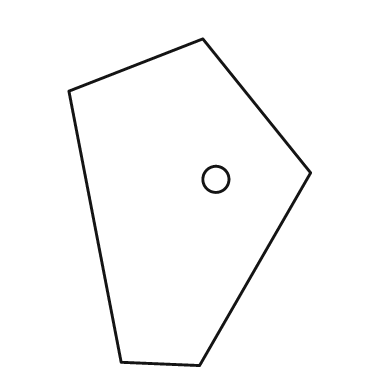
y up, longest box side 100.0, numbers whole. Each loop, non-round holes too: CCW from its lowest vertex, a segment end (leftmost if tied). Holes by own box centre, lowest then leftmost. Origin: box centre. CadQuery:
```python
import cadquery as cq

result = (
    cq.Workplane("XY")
    .moveTo(3.0, -50.0)
    .lineTo(37.0, 9.0)
    .lineTo(4.0, 50.0)
    .lineTo(-37.0, 34.0)
    .lineTo(-21.0, -49.0)
    .close()
    .moveTo(8.0, 7.0)
    .circle(4.0)
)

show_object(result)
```